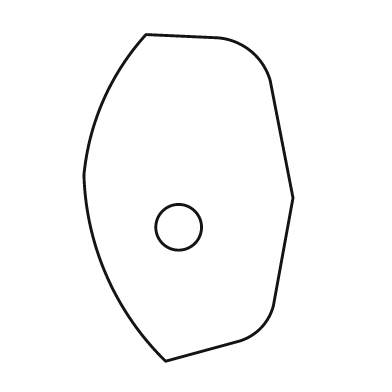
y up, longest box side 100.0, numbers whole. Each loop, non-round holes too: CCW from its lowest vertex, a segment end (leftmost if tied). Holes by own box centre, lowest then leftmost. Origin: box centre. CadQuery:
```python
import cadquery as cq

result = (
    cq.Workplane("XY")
    .moveTo(-7.0, -50.0)
    .lineTo(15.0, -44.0)
    .threePointArc((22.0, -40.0), (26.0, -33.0))
    .lineTo(32.0, 0.0)
    .lineTo(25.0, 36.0)
    .threePointArc((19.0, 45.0), (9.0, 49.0))
    .lineTo(-13.0, 50.0)
    .threePointArc((-26.0, 30.0), (-32.0, 7.0))
    .threePointArc((-25.0, -24.0), (-7.0, -50.0))
    .close()
    .moveTo(-3.0, -9.0)
    .circle(7.0)
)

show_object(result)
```